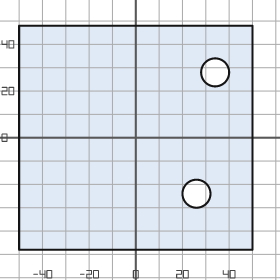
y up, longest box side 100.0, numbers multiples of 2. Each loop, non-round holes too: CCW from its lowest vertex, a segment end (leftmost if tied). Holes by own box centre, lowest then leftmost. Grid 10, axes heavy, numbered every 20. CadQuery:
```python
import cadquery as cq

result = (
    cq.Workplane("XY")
    .moveTo(-50.0, -48.0)
    .lineTo(50.0, -48.0)
    .lineTo(50.0, 48.0)
    .lineTo(-50.0, 48.0)
    .close()
    .moveTo(26.0, -24.0)
    .circle(6.0)
    .moveTo(34.0, 28.0)
    .circle(6.0)
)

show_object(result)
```